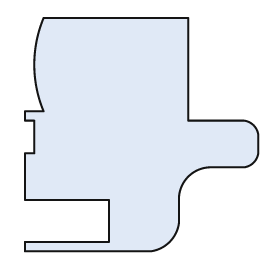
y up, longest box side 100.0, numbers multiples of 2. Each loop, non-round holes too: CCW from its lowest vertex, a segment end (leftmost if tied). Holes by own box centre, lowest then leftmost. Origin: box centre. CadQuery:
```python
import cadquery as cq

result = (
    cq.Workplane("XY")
    .moveTo(-50.0, -50.0)
    .lineTo(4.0, -50.0)
    .threePointArc((12.0, -46.0), (16.0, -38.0))
    .lineTo(16.0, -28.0)
    .threePointArc((20.0, -18.0), (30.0, -14.0))
    .lineTo(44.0, -14.0)
    .threePointArc((48.0, -12.0), (50.0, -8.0))
    .lineTo(50.0, 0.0)
    .threePointArc((48.0, 4.0), (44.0, 6.0))
    .lineTo(20.0, 6.0)
    .lineTo(20.0, 50.0)
    .lineTo(-42.0, 50.0)
    .threePointArc((-46.0, 30.0), (-42.0, 10.0))
    .lineTo(-50.0, 10.0)
    .lineTo(-50.0, 6.0)
    .lineTo(-46.0, 6.0)
    .lineTo(-46.0, -8.0)
    .lineTo(-50.0, -8.0)
    .lineTo(-50.0, -28.0)
    .lineTo(-14.0, -28.0)
    .lineTo(-14.0, -46.0)
    .lineTo(-50.0, -46.0)
    .close()
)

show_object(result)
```